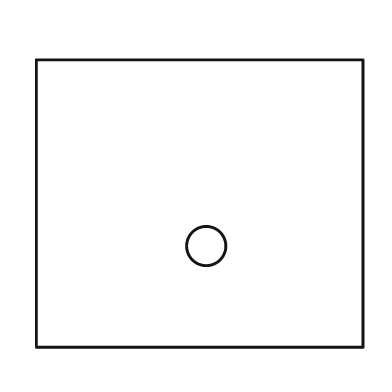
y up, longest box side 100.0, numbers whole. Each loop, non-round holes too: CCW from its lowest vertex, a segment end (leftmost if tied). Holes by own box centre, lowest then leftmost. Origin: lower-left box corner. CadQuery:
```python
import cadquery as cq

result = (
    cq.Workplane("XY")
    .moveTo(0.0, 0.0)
    .lineTo(100.0, 0.0)
    .lineTo(100.0, 88.0)
    .lineTo(0.0, 88.0)
    .close()
    .moveTo(52.0, 31.0)
    .circle(6.0)
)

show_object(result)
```